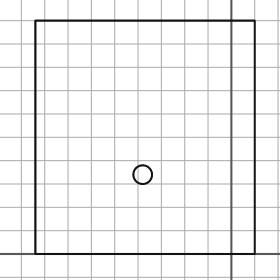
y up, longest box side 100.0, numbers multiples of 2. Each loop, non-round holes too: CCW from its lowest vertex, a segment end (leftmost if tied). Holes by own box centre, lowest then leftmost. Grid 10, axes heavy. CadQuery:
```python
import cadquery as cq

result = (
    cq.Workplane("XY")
    .moveTo(-84.0, 0.0)
    .lineTo(10.0, 0.0)
    .lineTo(10.0, 100.0)
    .lineTo(-84.0, 100.0)
    .close()
    .moveTo(-38.0, 34.0)
    .circle(4.0)
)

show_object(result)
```